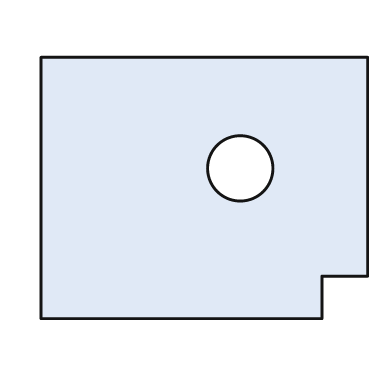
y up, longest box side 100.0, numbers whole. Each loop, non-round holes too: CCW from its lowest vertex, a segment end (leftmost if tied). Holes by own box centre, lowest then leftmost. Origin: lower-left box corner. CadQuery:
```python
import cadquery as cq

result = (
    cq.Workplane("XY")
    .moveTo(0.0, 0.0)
    .lineTo(86.0, 0.0)
    .lineTo(86.0, 13.0)
    .lineTo(100.0, 13.0)
    .lineTo(100.0, 80.0)
    .lineTo(0.0, 80.0)
    .close()
    .moveTo(61.0, 46.0)
    .circle(10.0)
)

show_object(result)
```